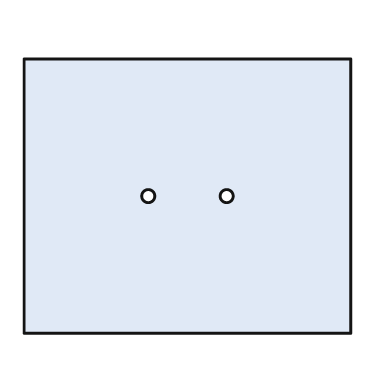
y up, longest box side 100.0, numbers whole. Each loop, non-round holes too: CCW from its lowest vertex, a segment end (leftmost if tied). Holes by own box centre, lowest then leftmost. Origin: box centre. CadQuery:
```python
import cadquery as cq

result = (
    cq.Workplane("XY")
    .moveTo(-50.0, -42.0)
    .lineTo(50.0, -42.0)
    .lineTo(50.0, 42.0)
    .lineTo(-50.0, 42.0)
    .close()
    .moveTo(-12.0, 0.0)
    .circle(2.0)
    .moveTo(12.0, 0.0)
    .circle(2.0)
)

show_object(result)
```